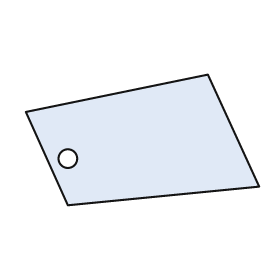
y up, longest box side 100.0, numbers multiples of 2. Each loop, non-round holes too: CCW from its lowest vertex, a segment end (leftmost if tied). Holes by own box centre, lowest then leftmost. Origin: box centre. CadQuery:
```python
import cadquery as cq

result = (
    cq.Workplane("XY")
    .moveTo(-32.0, -28.0)
    .lineTo(50.0, -20.0)
    .lineTo(28.0, 28.0)
    .lineTo(-50.0, 12.0)
    .close()
    .moveTo(-32.0, -8.0)
    .circle(4.0)
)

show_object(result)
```